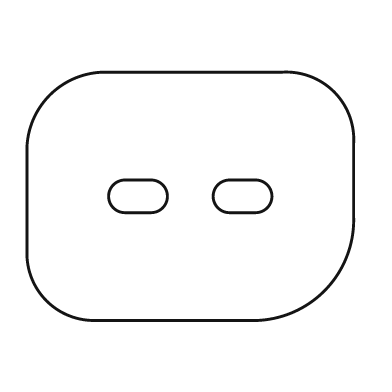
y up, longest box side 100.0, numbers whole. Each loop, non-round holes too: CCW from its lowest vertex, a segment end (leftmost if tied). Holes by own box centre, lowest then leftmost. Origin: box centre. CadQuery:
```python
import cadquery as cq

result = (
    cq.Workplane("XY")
    .moveTo(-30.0, -38.0)
    .lineTo(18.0, -38.0)
    .threePointArc((41.0, -29.0), (50.0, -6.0))
    .lineTo(50.0, 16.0)
    .threePointArc((44.0, 32.0), (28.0, 38.0))
    .lineTo(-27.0, 38.0)
    .threePointArc((-43.0, 31.0), (-50.0, 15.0))
    .lineTo(-50.0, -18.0)
    .threePointArc((-44.0, -32.0), (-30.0, -38.0))
    .close()
    .moveTo(-20.0, -5.0)
    .lineTo(-12.0, -5.0)
    .threePointArc((-7.0, 0.0), (-12.0, 5.0))
    .lineTo(-20.0, 5.0)
    .threePointArc((-25.0, 0.0), (-20.0, -5.0))
    .close()
    .moveTo(12.0, -5.0)
    .lineTo(20.0, -5.0)
    .threePointArc((25.0, 0.0), (20.0, 5.0))
    .lineTo(12.0, 5.0)
    .threePointArc((7.0, 0.0), (12.0, -5.0))
    .close()
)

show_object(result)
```